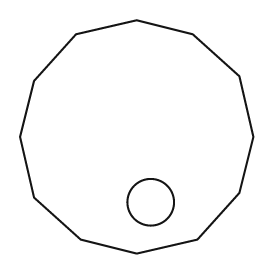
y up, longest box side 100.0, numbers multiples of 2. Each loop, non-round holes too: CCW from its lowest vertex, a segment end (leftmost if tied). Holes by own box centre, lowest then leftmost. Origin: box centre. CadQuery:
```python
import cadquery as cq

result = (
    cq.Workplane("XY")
    .moveTo(0.0, -50.0)
    .lineTo(26.0, -44.0)
    .lineTo(44.0, -24.0)
    .lineTo(50.0, 0.0)
    .lineTo(44.0, 26.0)
    .lineTo(24.0, 44.0)
    .lineTo(0.0, 50.0)
    .lineTo(-26.0, 44.0)
    .lineTo(-44.0, 24.0)
    .lineTo(-50.0, 0.0)
    .lineTo(-44.0, -26.0)
    .lineTo(-24.0, -44.0)
    .close()
    .moveTo(6.0, -28.0)
    .circle(10.0)
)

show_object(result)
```